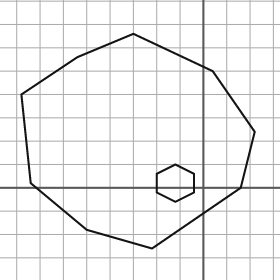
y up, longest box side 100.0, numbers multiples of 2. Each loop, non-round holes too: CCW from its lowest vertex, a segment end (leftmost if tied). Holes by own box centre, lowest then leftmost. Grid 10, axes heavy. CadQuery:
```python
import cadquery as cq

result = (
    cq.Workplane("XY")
    .moveTo(-22.0, -26.0)
    .lineTo(16.0, 0.0)
    .lineTo(22.0, 24.0)
    .lineTo(4.0, 50.0)
    .lineTo(-30.0, 66.0)
    .lineTo(-54.0, 56.0)
    .lineTo(-78.0, 40.0)
    .lineTo(-74.0, 2.0)
    .lineTo(-50.0, -18.0)
    .close()
    .moveTo(-12.0, -6.0)
    .lineTo(-4.0, -2.0)
    .lineTo(-4.0, 6.0)
    .lineTo(-12.0, 10.0)
    .lineTo(-20.0, 6.0)
    .lineTo(-20.0, -2.0)
    .close()
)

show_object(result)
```